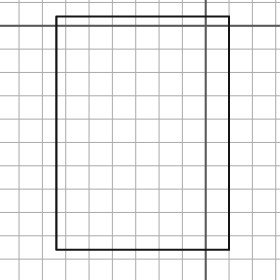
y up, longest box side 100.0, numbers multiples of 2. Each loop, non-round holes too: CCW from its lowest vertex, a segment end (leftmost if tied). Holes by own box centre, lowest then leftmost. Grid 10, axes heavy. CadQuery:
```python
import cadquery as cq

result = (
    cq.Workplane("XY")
    .moveTo(-64.0, -96.0)
    .lineTo(10.0, -96.0)
    .lineTo(10.0, 4.0)
    .lineTo(-64.0, 4.0)
    .close()
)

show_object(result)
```